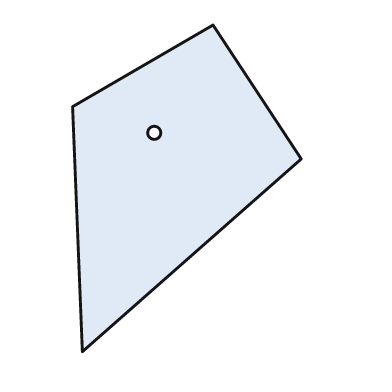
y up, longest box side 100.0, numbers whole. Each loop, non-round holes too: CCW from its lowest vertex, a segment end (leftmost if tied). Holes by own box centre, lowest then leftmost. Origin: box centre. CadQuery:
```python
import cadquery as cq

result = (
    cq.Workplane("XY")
    .moveTo(-32.0, -50.0)
    .lineTo(35.0, 9.0)
    .lineTo(8.0, 50.0)
    .lineTo(-35.0, 25.0)
    .close()
    .moveTo(-10.0, 17.0)
    .circle(2.0)
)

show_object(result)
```